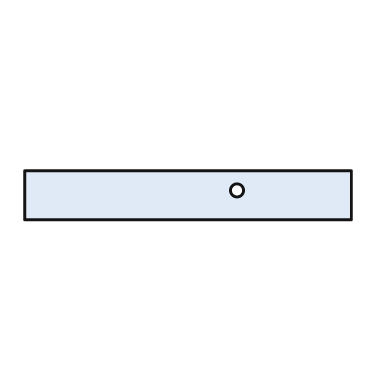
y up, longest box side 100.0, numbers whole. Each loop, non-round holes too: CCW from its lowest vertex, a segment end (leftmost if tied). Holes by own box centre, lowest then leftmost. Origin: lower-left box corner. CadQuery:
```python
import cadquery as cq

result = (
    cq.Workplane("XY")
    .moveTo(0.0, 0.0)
    .lineTo(100.0, 0.0)
    .lineTo(100.0, 15.0)
    .lineTo(0.0, 15.0)
    .close()
    .moveTo(65.0, 9.0)
    .circle(2.0)
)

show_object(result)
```